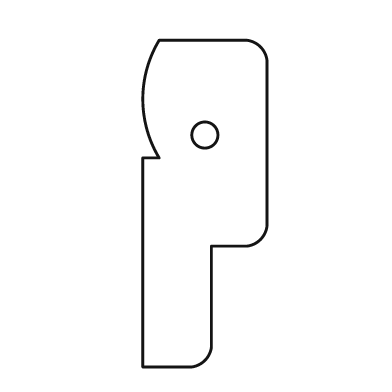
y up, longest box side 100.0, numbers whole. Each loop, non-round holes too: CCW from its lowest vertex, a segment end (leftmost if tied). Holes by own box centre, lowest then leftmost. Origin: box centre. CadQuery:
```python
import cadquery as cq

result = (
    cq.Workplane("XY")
    .moveTo(-19.0, -50.0)
    .lineTo(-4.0, -50.0)
    .threePointArc((0.0, -48.0), (2.0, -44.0))
    .lineTo(2.0, -13.0)
    .lineTo(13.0, -13.0)
    .threePointArc((17.0, -11.0), (19.0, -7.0))
    .lineTo(19.0, 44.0)
    .threePointArc((17.0, 48.0), (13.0, 50.0))
    .lineTo(-14.0, 50.0)
    .threePointArc((-19.0, 32.0), (-14.0, 14.0))
    .lineTo(-19.0, 14.0)
    .close()
    .moveTo(0.0, 21.0)
    .circle(4.0)
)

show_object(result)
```